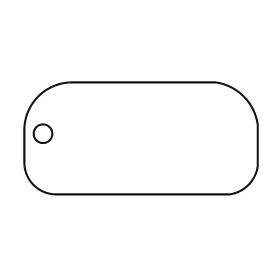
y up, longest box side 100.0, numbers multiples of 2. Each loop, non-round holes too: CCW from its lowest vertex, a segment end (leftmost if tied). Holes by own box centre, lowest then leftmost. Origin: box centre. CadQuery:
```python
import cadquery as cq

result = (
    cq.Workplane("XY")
    .moveTo(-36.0, -24.0)
    .lineTo(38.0, -24.0)
    .threePointArc((46.0, -20.0), (50.0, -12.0))
    .lineTo(50.0, 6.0)
    .threePointArc((44.0, 18.0), (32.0, 24.0))
    .lineTo(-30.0, 24.0)
    .threePointArc((-44.0, 18.0), (-50.0, 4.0))
    .lineTo(-50.0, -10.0)
    .threePointArc((-46.0, -20.0), (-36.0, -24.0))
    .close()
    .moveTo(-42.0, 2.0)
    .circle(4.0)
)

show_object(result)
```